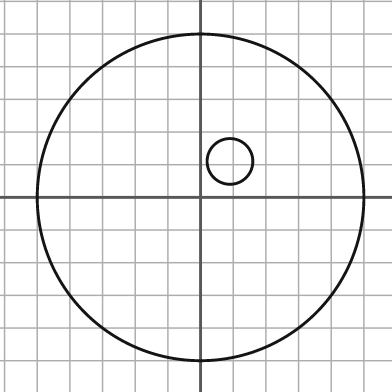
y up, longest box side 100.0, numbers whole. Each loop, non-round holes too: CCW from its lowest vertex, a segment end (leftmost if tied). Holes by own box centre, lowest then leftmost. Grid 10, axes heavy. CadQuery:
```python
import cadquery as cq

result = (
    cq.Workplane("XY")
    .moveTo(0.0, 0.0)
    .circle(50.0)
    .moveTo(9.0, 11.0)
    .circle(7.0)
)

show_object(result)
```